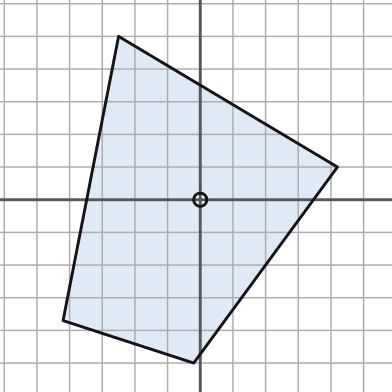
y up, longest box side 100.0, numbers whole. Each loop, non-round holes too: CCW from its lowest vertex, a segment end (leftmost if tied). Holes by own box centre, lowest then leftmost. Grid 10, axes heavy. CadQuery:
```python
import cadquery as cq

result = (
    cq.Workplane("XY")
    .moveTo(-2.0, -50.0)
    .lineTo(42.0, 10.0)
    .lineTo(-25.0, 50.0)
    .lineTo(-42.0, -37.0)
    .close()
    .moveTo(0.0, 0.0)
    .circle(2.0)
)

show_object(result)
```